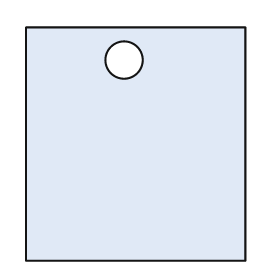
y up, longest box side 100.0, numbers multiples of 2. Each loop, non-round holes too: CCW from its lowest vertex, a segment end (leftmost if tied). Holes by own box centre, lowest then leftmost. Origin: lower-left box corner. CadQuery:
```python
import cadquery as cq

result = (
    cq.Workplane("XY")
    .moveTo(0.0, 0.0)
    .lineTo(94.0, 0.0)
    .lineTo(94.0, 100.0)
    .lineTo(0.0, 100.0)
    .close()
    .moveTo(42.0, 86.0)
    .circle(8.0)
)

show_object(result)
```